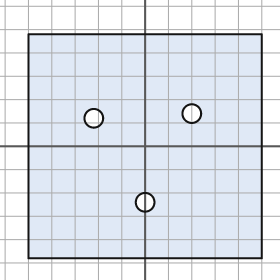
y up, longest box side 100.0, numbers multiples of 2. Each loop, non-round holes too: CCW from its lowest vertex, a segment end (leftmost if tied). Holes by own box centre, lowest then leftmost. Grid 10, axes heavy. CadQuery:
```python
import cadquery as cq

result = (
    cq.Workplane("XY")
    .moveTo(-50.0, -48.0)
    .lineTo(50.0, -48.0)
    .lineTo(50.0, 48.0)
    .lineTo(-50.0, 48.0)
    .close()
    .moveTo(0.0, -24.0)
    .circle(4.0)
    .moveTo(-22.0, 12.0)
    .circle(4.0)
    .moveTo(20.0, 14.0)
    .circle(4.0)
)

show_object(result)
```